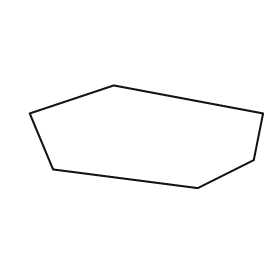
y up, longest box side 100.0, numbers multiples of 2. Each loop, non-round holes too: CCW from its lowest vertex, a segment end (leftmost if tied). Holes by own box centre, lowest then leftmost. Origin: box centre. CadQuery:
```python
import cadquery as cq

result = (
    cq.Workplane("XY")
    .moveTo(22.0, -22.0)
    .lineTo(46.0, -10.0)
    .lineTo(50.0, 10.0)
    .lineTo(-14.0, 22.0)
    .lineTo(-50.0, 10.0)
    .lineTo(-40.0, -14.0)
    .close()
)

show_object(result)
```